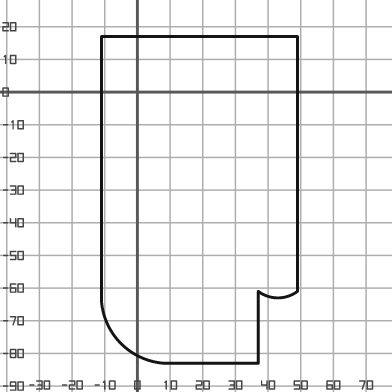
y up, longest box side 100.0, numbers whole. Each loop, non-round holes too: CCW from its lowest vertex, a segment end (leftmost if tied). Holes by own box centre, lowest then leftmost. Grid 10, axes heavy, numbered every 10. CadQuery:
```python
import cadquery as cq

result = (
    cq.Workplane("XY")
    .moveTo(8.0, -83.0)
    .lineTo(37.0, -83.0)
    .lineTo(37.0, -61.0)
    .threePointArc((43.0, -63.0), (49.0, -61.0))
    .lineTo(49.0, 17.0)
    .lineTo(-11.0, 17.0)
    .lineTo(-11.0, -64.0)
    .threePointArc((-5.0, -77.0), (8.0, -83.0))
    .close()
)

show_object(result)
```